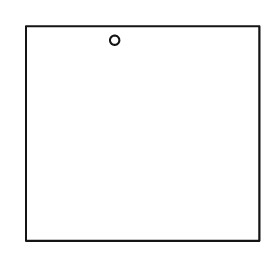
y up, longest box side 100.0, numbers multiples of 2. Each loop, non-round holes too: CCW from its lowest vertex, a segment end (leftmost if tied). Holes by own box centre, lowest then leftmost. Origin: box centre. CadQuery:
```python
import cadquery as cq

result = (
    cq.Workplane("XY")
    .moveTo(-50.0, -46.0)
    .lineTo(50.0, -46.0)
    .lineTo(50.0, 46.0)
    .lineTo(-50.0, 46.0)
    .close()
    .moveTo(-12.0, 40.0)
    .circle(2.0)
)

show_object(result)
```